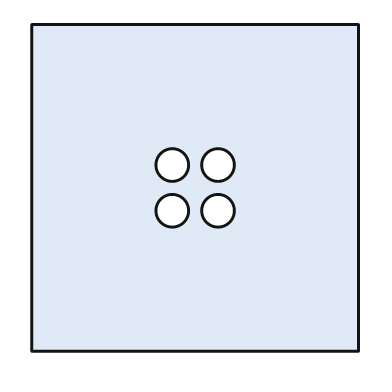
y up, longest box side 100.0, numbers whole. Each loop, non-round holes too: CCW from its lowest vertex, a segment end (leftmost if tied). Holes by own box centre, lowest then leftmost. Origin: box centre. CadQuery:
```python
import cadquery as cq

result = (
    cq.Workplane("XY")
    .moveTo(-50.0, -50.0)
    .lineTo(50.0, -50.0)
    .lineTo(50.0, 50.0)
    .lineTo(-50.0, 50.0)
    .close()
    .moveTo(-7.0, -7.0)
    .circle(5.0)
    .moveTo(7.0, -7.0)
    .circle(5.0)
    .moveTo(-7.0, 7.0)
    .circle(5.0)
    .moveTo(7.0, 7.0)
    .circle(5.0)
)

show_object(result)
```